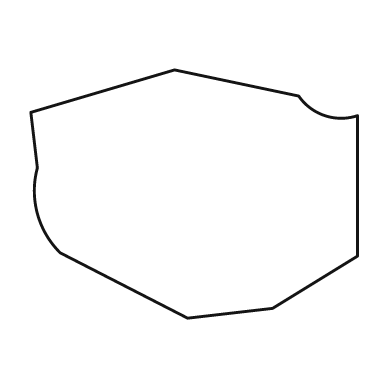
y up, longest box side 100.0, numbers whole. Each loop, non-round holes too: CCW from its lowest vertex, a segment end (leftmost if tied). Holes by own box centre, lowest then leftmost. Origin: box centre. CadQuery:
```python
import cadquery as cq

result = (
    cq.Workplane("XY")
    .moveTo(-2.0, -38.0)
    .lineTo(24.0, -35.0)
    .lineTo(50.0, -19.0)
    .lineTo(50.0, 24.0)
    .threePointArc((40.0, 24.0), (32.0, 30.0))
    .lineTo(-6.0, 38.0)
    .lineTo(-50.0, 25.0)
    .lineTo(-48.0, 8.0)
    .threePointArc((-48.0, -6.0), (-41.0, -18.0))
    .close()
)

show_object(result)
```